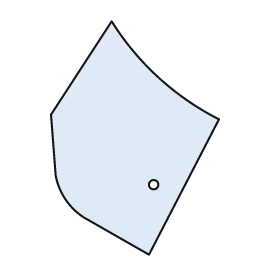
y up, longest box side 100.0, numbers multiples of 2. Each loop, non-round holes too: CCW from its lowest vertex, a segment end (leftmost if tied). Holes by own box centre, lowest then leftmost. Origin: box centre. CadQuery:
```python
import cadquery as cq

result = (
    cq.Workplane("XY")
    .moveTo(6.0, -50.0)
    .lineTo(36.0, 8.0)
    .threePointArc((10.0, 26.0), (-10.0, 50.0))
    .lineTo(-36.0, 10.0)
    .lineTo(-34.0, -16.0)
    .threePointArc((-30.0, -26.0), (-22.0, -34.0))
    .close()
    .moveTo(8.0, -20.0)
    .circle(2.0)
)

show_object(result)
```